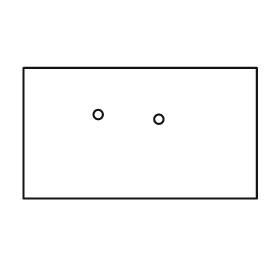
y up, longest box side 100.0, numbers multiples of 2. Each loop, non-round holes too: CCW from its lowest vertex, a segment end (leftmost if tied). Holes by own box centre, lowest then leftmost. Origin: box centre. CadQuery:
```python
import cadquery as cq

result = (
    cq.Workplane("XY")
    .moveTo(-50.0, -28.0)
    .lineTo(50.0, -28.0)
    .lineTo(50.0, 28.0)
    .lineTo(-50.0, 28.0)
    .close()
    .moveTo(8.0, 6.0)
    .circle(2.0)
    .moveTo(-18.0, 8.0)
    .circle(2.0)
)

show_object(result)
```